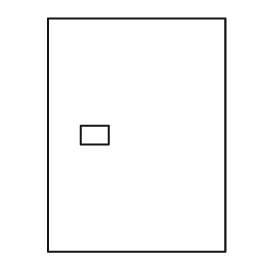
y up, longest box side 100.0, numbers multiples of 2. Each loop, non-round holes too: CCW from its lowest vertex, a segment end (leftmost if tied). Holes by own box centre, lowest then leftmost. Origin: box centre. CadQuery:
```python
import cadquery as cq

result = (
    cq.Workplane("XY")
    .moveTo(-38.0, -50.0)
    .lineTo(38.0, -50.0)
    .lineTo(38.0, 50.0)
    .lineTo(-38.0, 50.0)
    .close()
    .moveTo(-24.0, -4.0)
    .lineTo(-12.0, -4.0)
    .lineTo(-12.0, 4.0)
    .lineTo(-24.0, 4.0)
    .close()
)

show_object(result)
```